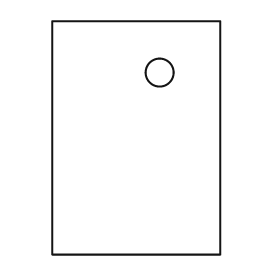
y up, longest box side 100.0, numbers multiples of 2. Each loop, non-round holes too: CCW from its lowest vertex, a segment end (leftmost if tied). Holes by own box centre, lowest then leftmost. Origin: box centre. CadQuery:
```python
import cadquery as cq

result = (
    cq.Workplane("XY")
    .moveTo(-36.0, -50.0)
    .lineTo(36.0, -50.0)
    .lineTo(36.0, 50.0)
    .lineTo(-36.0, 50.0)
    .close()
    .moveTo(10.0, 28.0)
    .circle(6.0)
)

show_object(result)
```